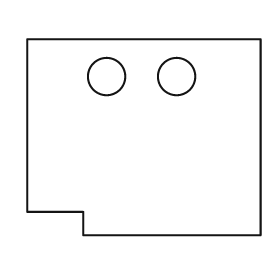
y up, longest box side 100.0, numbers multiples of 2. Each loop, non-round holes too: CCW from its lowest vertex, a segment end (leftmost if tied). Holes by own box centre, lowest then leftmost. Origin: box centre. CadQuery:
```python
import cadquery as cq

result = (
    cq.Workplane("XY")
    .moveTo(-26.0, -42.0)
    .lineTo(50.0, -42.0)
    .lineTo(50.0, 42.0)
    .lineTo(-50.0, 42.0)
    .lineTo(-50.0, -32.0)
    .lineTo(-26.0, -32.0)
    .close()
    .moveTo(-16.0, 26.0)
    .circle(8.0)
    .moveTo(14.0, 26.0)
    .circle(8.0)
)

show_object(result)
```